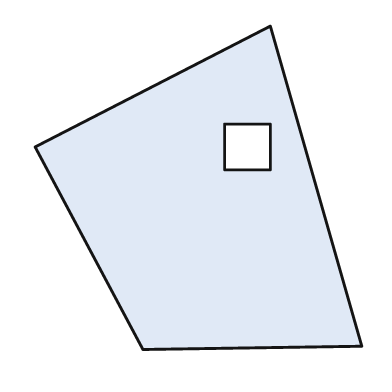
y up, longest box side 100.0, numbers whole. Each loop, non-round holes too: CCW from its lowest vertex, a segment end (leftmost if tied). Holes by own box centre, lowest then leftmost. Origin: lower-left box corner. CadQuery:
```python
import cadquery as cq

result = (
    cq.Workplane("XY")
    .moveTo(33.0, 0.0)
    .lineTo(100.0, 1.0)
    .lineTo(72.0, 99.0)
    .lineTo(0.0, 62.0)
    .close()
    .moveTo(58.0, 55.0)
    .lineTo(72.0, 55.0)
    .lineTo(72.0, 69.0)
    .lineTo(58.0, 69.0)
    .close()
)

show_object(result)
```